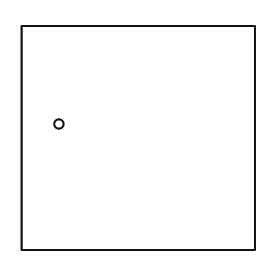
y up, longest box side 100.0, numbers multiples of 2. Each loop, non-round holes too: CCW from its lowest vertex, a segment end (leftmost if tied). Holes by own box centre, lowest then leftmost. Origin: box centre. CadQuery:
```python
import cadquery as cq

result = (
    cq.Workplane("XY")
    .moveTo(-50.0, -48.0)
    .lineTo(50.0, -48.0)
    .lineTo(50.0, 48.0)
    .lineTo(-50.0, 48.0)
    .close()
    .moveTo(-34.0, 6.0)
    .circle(2.0)
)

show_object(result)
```